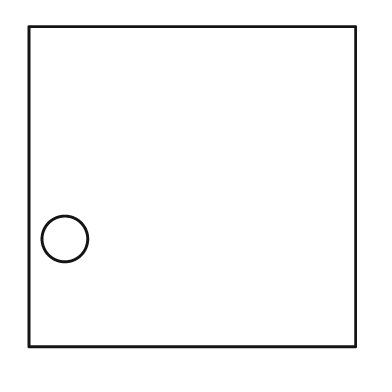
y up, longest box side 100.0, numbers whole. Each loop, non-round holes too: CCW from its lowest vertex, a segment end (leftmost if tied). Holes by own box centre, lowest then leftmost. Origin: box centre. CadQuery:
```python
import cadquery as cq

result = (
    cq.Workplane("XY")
    .moveTo(-50.0, -49.0)
    .lineTo(50.0, -49.0)
    .lineTo(50.0, 49.0)
    .lineTo(-50.0, 49.0)
    .close()
    .moveTo(-39.0, -16.0)
    .circle(7.0)
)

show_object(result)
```